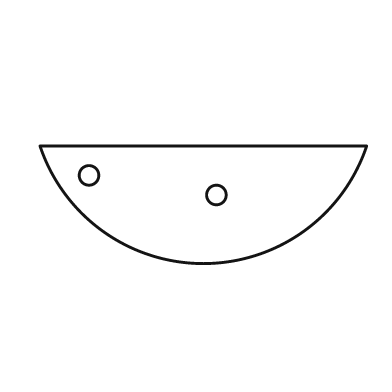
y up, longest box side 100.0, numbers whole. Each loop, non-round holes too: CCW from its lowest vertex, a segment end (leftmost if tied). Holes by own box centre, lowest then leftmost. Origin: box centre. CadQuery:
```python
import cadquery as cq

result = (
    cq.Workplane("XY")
    .moveTo(-50.0, 18.0)
    .threePointArc((0.0, -18.0), (50.0, 18.0))
    .close()
    .moveTo(4.0, 3.0)
    .circle(3.0)
    .moveTo(-35.0, 9.0)
    .circle(3.0)
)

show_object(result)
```